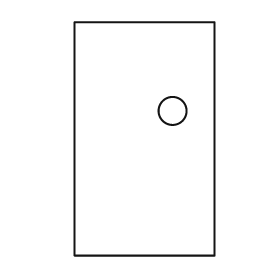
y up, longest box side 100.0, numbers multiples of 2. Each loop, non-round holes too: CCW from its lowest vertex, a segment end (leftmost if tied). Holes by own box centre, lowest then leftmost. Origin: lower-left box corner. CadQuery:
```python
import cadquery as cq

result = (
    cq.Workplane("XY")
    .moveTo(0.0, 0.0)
    .lineTo(60.0, 0.0)
    .lineTo(60.0, 100.0)
    .lineTo(0.0, 100.0)
    .close()
    .moveTo(42.0, 62.0)
    .circle(6.0)
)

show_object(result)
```